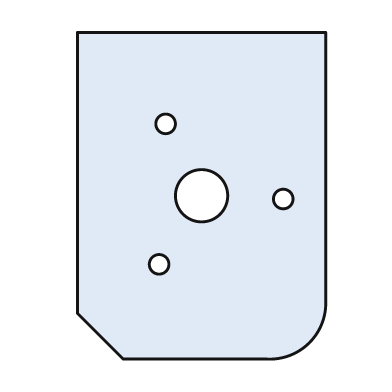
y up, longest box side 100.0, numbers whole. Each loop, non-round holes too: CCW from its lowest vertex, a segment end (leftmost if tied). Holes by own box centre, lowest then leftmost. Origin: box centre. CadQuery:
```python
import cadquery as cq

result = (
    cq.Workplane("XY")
    .moveTo(-24.0, -50.0)
    .lineTo(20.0, -50.0)
    .threePointArc((33.0, -45.0), (38.0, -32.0))
    .lineTo(38.0, 50.0)
    .lineTo(-38.0, 50.0)
    .lineTo(-38.0, -36.0)
    .close()
    .moveTo(-13.0, -21.0)
    .circle(3.0)
    .moveTo(25.0, -1.0)
    .circle(3.0)
    .moveTo(0.0, 0.0)
    .circle(8.0)
    .moveTo(-11.0, 22.0)
    .circle(3.0)
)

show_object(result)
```